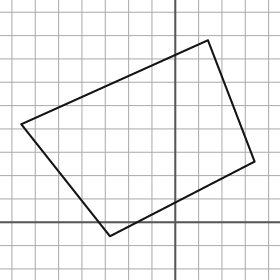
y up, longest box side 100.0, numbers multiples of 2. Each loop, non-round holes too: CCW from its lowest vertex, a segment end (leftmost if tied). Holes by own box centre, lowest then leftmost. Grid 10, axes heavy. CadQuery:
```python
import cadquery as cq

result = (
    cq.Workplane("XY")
    .moveTo(-28.0, -6.0)
    .lineTo(34.0, 26.0)
    .lineTo(14.0, 78.0)
    .lineTo(-66.0, 42.0)
    .close()
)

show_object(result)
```